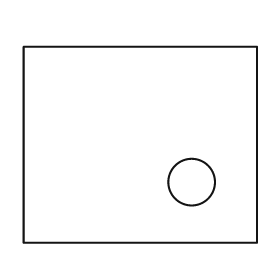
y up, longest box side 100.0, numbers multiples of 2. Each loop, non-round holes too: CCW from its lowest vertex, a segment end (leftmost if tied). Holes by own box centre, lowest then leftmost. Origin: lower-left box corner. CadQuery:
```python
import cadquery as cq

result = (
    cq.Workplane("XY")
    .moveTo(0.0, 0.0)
    .lineTo(100.0, 0.0)
    .lineTo(100.0, 84.0)
    .lineTo(0.0, 84.0)
    .close()
    .moveTo(72.0, 26.0)
    .circle(10.0)
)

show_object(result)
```